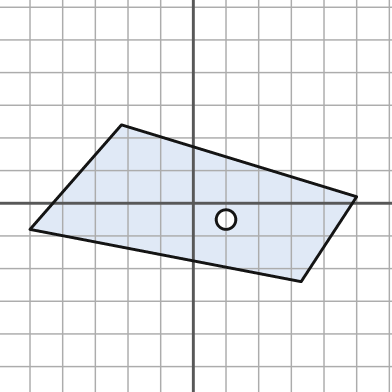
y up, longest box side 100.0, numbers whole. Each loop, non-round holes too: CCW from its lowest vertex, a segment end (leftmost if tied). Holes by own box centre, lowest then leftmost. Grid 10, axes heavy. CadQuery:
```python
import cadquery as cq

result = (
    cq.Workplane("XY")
    .moveTo(33.0, -24.0)
    .lineTo(50.0, 2.0)
    .lineTo(-22.0, 24.0)
    .lineTo(-50.0, -8.0)
    .close()
    .moveTo(10.0, -5.0)
    .circle(3.0)
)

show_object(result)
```